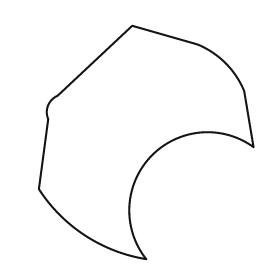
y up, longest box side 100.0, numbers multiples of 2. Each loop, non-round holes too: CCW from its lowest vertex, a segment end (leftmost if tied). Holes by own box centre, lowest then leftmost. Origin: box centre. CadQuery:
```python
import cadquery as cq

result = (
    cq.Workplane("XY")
    .moveTo(0.0, -50.0)
    .threePointArc((2.0, -6.0), (46.0, -2.0))
    .lineTo(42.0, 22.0)
    .threePointArc((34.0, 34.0), (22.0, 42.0))
    .lineTo(-6.0, 50.0)
    .lineTo(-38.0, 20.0)
    .threePointArc((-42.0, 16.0), (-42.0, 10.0))
    .lineTo(-46.0, -20.0)
    .threePointArc((-26.0, -40.0), (0.0, -50.0))
    .close()
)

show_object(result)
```